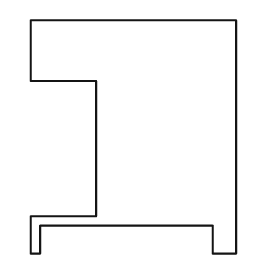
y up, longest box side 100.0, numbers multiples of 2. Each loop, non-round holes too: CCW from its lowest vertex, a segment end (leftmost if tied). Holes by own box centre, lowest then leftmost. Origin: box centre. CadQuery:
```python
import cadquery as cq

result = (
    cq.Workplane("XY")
    .moveTo(-44.0, -50.0)
    .lineTo(-40.0, -50.0)
    .lineTo(-40.0, -38.0)
    .lineTo(34.0, -38.0)
    .lineTo(34.0, -50.0)
    .lineTo(44.0, -50.0)
    .lineTo(44.0, 50.0)
    .lineTo(-44.0, 50.0)
    .lineTo(-44.0, 24.0)
    .lineTo(-16.0, 24.0)
    .lineTo(-16.0, -34.0)
    .lineTo(-44.0, -34.0)
    .close()
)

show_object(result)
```